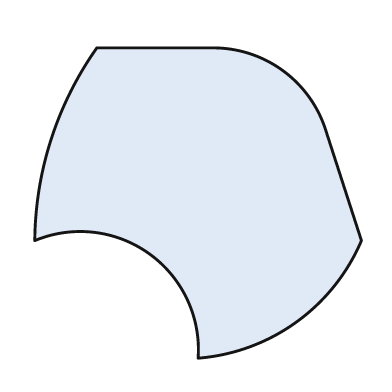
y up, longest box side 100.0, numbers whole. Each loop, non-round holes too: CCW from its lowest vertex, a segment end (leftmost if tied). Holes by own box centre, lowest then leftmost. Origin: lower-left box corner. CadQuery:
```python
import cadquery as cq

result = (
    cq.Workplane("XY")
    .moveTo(50.0, 0.0)
    .threePointArc((80.0, 11.0), (100.0, 36.0))
    .lineTo(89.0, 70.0)
    .threePointArc((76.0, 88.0), (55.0, 95.0))
    .lineTo(19.0, 95.0)
    .threePointArc((5.0, 67.0), (0.0, 36.0))
    .threePointArc((35.0, 32.0), (50.0, 0.0))
    .close()
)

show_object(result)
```